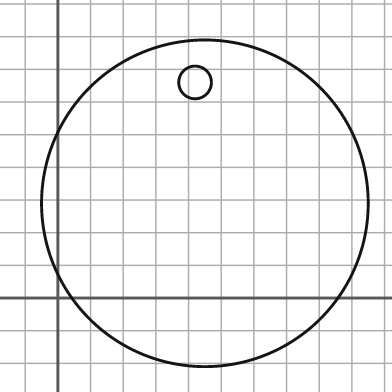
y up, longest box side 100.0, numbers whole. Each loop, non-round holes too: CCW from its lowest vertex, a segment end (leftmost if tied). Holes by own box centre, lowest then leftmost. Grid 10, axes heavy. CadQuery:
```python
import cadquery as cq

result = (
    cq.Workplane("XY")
    .moveTo(45.0, 29.0)
    .circle(50.0)
    .moveTo(42.0, 66.0)
    .circle(5.0)
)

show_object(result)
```